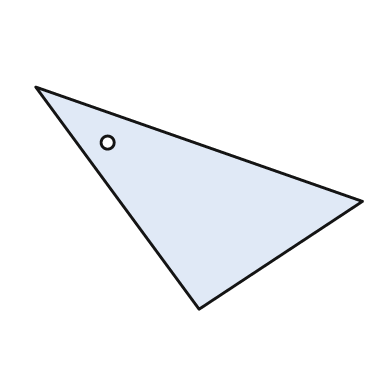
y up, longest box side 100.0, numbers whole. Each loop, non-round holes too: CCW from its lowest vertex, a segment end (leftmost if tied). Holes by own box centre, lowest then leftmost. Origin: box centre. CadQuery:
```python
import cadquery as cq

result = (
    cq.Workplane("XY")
    .moveTo(0.0, -34.0)
    .lineTo(50.0, -1.0)
    .lineTo(-50.0, 34.0)
    .close()
    .moveTo(-28.0, 17.0)
    .circle(2.0)
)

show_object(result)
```